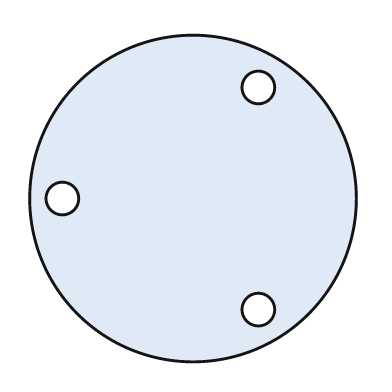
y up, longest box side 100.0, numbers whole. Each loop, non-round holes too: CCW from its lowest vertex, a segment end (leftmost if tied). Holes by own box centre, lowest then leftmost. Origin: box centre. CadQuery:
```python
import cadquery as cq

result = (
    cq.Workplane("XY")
    .moveTo(0.0, 0.0)
    .circle(50.0)
    .moveTo(20.0, -34.0)
    .circle(5.0)
    .moveTo(-40.0, 0.0)
    .circle(5.0)
    .moveTo(20.0, 34.0)
    .circle(5.0)
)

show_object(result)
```